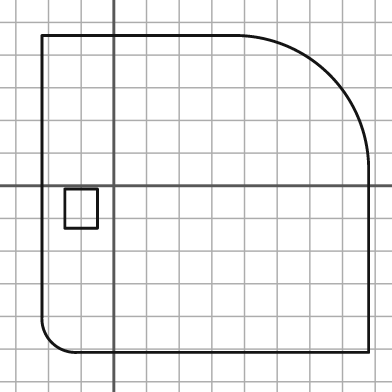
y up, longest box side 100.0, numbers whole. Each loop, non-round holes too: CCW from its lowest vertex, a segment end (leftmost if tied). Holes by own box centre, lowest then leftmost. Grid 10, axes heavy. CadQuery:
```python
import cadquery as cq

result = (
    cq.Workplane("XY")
    .moveTo(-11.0, -51.0)
    .lineTo(78.0, -51.0)
    .lineTo(78.0, 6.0)
    .threePointArc((66.0, 34.0), (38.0, 46.0))
    .lineTo(-22.0, 46.0)
    .lineTo(-22.0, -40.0)
    .threePointArc((-19.0, -48.0), (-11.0, -51.0))
    .close()
    .moveTo(-15.0, -13.0)
    .lineTo(-5.0, -13.0)
    .lineTo(-5.0, -1.0)
    .lineTo(-15.0, -1.0)
    .close()
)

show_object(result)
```